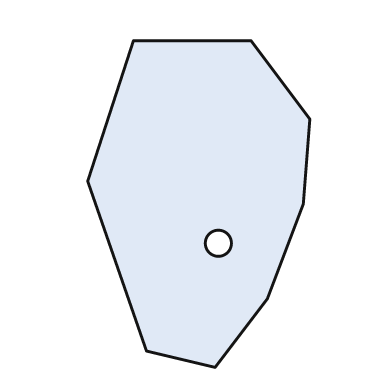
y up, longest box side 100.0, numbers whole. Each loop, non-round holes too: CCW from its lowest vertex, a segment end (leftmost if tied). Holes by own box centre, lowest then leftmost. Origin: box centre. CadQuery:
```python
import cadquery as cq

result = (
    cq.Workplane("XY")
    .moveTo(5.0, -50.0)
    .lineTo(21.0, -29.0)
    .lineTo(32.0, 0.0)
    .lineTo(34.0, 26.0)
    .lineTo(16.0, 50.0)
    .lineTo(-20.0, 50.0)
    .lineTo(-34.0, 7.0)
    .lineTo(-16.0, -45.0)
    .close()
    .moveTo(6.0, -12.0)
    .circle(4.0)
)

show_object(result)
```